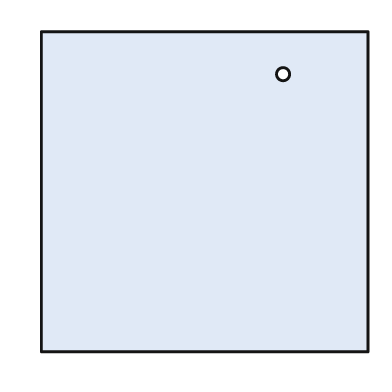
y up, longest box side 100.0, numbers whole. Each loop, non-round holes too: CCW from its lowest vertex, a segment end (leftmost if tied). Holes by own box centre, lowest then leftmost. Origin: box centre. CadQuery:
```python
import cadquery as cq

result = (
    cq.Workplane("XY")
    .moveTo(-50.0, -49.0)
    .lineTo(50.0, -49.0)
    .lineTo(50.0, 49.0)
    .lineTo(-50.0, 49.0)
    .close()
    .moveTo(24.0, 36.0)
    .circle(2.0)
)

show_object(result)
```